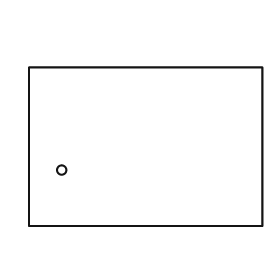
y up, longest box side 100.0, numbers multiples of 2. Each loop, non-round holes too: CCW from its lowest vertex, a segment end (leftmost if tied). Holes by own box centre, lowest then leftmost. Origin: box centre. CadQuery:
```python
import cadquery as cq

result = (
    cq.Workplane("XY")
    .moveTo(-50.0, -34.0)
    .lineTo(50.0, -34.0)
    .lineTo(50.0, 34.0)
    .lineTo(-50.0, 34.0)
    .close()
    .moveTo(-36.0, -10.0)
    .circle(2.0)
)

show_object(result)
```